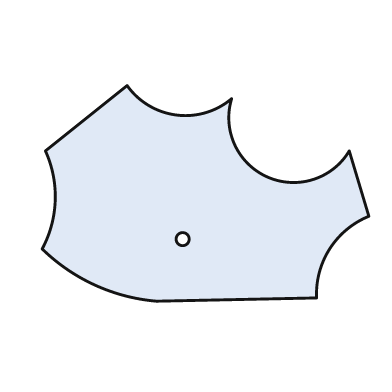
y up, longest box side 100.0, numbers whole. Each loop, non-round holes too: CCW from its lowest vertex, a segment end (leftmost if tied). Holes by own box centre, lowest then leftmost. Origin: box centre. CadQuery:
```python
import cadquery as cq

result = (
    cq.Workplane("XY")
    .moveTo(-15.0, -33.0)
    .lineTo(34.0, -32.0)
    .threePointArc((38.0, -17.0), (50.0, -7.0))
    .lineTo(44.0, 13.0)
    .threePointArc((19.0, 5.0), (8.0, 29.0))
    .threePointArc((-9.0, 24.0), (-24.0, 33.0))
    .lineTo(-49.0, 13.0)
    .threePointArc((-46.0, -2.0), (-50.0, -17.0))
    .threePointArc((-34.0, -28.0), (-15.0, -33.0))
    .close()
    .moveTo(-7.0, -14.0)
    .circle(2.0)
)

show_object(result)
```